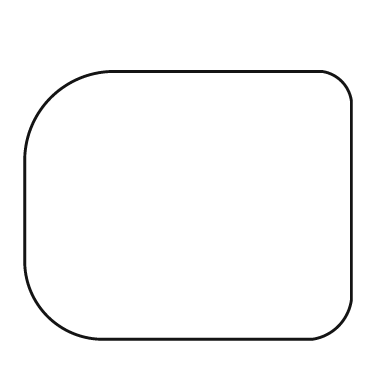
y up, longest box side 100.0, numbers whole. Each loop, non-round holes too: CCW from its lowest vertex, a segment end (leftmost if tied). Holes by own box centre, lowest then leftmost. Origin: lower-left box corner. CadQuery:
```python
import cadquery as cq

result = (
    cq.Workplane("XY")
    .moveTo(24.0, 0.0)
    .lineTo(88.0, 0.0)
    .threePointArc((96.0, 4.0), (100.0, 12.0))
    .lineTo(100.0, 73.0)
    .threePointArc((97.0, 79.0), (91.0, 82.0))
    .lineTo(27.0, 82.0)
    .threePointArc((8.0, 74.0), (0.0, 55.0))
    .lineTo(0.0, 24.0)
    .threePointArc((7.0, 7.0), (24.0, 0.0))
    .close()
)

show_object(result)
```